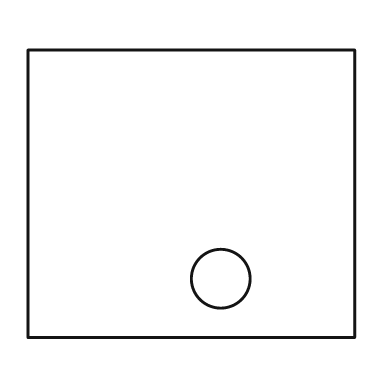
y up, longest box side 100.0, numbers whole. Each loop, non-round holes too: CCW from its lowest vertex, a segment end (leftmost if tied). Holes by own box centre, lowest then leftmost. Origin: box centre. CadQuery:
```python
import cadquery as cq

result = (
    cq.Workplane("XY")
    .moveTo(-50.0, -44.0)
    .lineTo(50.0, -44.0)
    .lineTo(50.0, 44.0)
    .lineTo(-50.0, 44.0)
    .close()
    .moveTo(9.0, -26.0)
    .circle(9.0)
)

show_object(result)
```